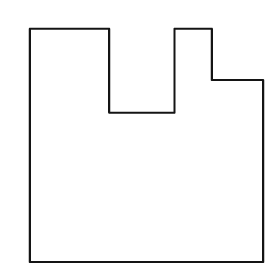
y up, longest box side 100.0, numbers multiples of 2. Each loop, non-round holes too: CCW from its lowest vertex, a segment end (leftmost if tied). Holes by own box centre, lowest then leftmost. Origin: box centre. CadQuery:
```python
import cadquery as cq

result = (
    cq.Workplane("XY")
    .moveTo(-50.0, -50.0)
    .lineTo(50.0, -50.0)
    .lineTo(50.0, 28.0)
    .lineTo(28.0, 28.0)
    .lineTo(28.0, 50.0)
    .lineTo(12.0, 50.0)
    .lineTo(12.0, 14.0)
    .lineTo(-16.0, 14.0)
    .lineTo(-16.0, 50.0)
    .lineTo(-50.0, 50.0)
    .close()
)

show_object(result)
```